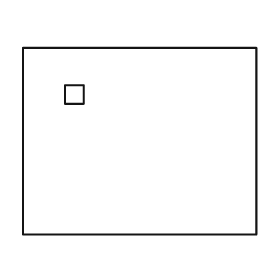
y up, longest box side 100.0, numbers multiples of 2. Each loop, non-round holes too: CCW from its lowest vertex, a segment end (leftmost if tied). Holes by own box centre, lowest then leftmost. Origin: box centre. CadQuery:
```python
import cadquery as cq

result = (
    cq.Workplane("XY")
    .moveTo(-50.0, -40.0)
    .lineTo(50.0, -40.0)
    .lineTo(50.0, 40.0)
    .lineTo(-50.0, 40.0)
    .close()
    .moveTo(-32.0, 16.0)
    .lineTo(-24.0, 16.0)
    .lineTo(-24.0, 24.0)
    .lineTo(-32.0, 24.0)
    .close()
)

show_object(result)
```